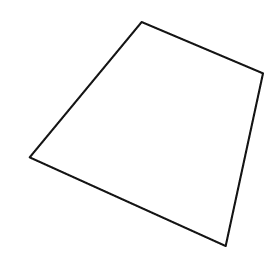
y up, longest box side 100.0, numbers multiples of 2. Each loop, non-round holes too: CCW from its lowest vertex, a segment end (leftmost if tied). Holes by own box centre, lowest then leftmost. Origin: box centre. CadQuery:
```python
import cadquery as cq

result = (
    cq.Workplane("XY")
    .moveTo(34.0, -48.0)
    .lineTo(50.0, 26.0)
    .lineTo(-2.0, 48.0)
    .lineTo(-50.0, -10.0)
    .close()
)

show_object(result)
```